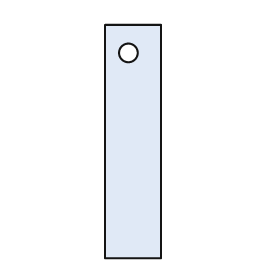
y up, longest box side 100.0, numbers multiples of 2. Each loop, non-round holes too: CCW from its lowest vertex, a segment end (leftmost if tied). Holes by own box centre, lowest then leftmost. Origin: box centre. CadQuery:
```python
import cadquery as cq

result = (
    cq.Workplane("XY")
    .moveTo(-12.0, -50.0)
    .lineTo(12.0, -50.0)
    .lineTo(12.0, 50.0)
    .lineTo(-12.0, 50.0)
    .close()
    .moveTo(-2.0, 38.0)
    .circle(4.0)
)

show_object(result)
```